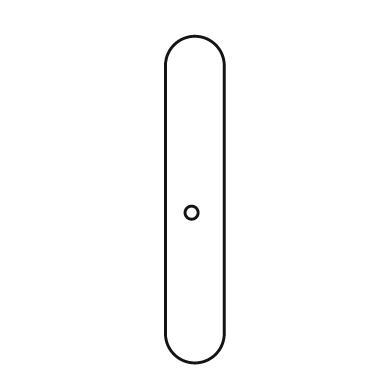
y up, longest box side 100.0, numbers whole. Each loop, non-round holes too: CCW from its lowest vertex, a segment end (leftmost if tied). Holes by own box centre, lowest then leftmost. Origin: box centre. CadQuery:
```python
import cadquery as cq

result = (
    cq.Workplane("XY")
    .moveTo(-9.0, -41.0)
    .threePointArc((0.0, -50.0), (9.0, -41.0))
    .lineTo(9.0, 41.0)
    .threePointArc((0.0, 50.0), (-9.0, 41.0))
    .close()
    .moveTo(-1.0, -4.0)
    .circle(2.0)
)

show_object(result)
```